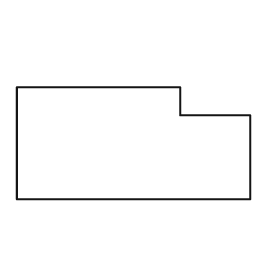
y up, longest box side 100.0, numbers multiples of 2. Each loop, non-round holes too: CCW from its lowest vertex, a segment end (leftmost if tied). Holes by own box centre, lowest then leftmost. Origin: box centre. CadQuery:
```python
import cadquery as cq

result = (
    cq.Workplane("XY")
    .moveTo(-50.0, -24.0)
    .lineTo(50.0, -24.0)
    .lineTo(50.0, 12.0)
    .lineTo(20.0, 12.0)
    .lineTo(20.0, 24.0)
    .lineTo(-50.0, 24.0)
    .close()
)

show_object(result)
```